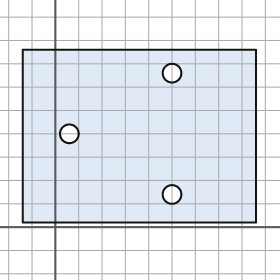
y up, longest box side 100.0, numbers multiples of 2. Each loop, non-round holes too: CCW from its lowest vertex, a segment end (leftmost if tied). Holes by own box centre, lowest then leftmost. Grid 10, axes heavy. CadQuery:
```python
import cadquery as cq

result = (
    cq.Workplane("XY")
    .moveTo(-14.0, 2.0)
    .lineTo(86.0, 2.0)
    .lineTo(86.0, 76.0)
    .lineTo(-14.0, 76.0)
    .close()
    .moveTo(50.0, 14.0)
    .circle(4.0)
    .moveTo(6.0, 40.0)
    .circle(4.0)
    .moveTo(50.0, 66.0)
    .circle(4.0)
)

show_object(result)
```